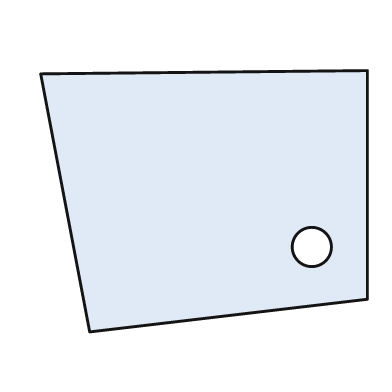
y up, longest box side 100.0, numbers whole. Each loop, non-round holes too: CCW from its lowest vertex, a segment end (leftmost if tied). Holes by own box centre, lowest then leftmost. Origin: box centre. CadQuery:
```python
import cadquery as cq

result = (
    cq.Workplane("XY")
    .moveTo(-35.0, -40.0)
    .lineTo(50.0, -30.0)
    .lineTo(50.0, 40.0)
    .lineTo(-50.0, 39.0)
    .close()
    .moveTo(33.0, -14.0)
    .circle(6.0)
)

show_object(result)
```